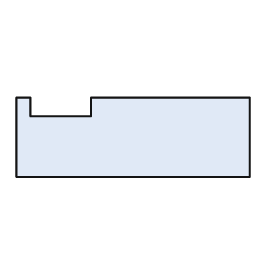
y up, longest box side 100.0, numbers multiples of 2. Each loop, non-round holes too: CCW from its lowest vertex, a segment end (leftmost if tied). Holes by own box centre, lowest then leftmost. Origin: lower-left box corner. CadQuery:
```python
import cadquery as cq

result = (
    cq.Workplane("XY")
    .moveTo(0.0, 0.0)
    .lineTo(100.0, 0.0)
    .lineTo(100.0, 34.0)
    .lineTo(32.0, 34.0)
    .lineTo(32.0, 26.0)
    .lineTo(6.0, 26.0)
    .lineTo(6.0, 34.0)
    .lineTo(0.0, 34.0)
    .close()
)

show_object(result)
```